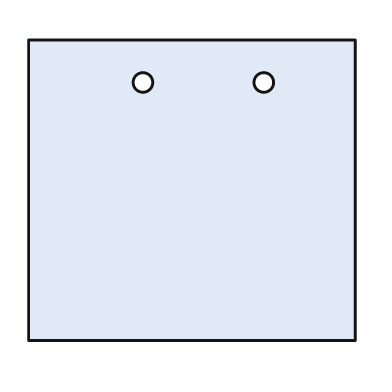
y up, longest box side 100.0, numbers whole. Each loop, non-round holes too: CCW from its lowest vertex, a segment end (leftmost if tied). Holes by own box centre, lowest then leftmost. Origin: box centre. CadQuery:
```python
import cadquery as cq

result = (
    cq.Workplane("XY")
    .moveTo(-50.0, -46.0)
    .lineTo(50.0, -46.0)
    .lineTo(50.0, 46.0)
    .lineTo(-50.0, 46.0)
    .close()
    .moveTo(-15.0, 33.0)
    .circle(3.0)
    .moveTo(22.0, 33.0)
    .circle(3.0)
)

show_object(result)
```